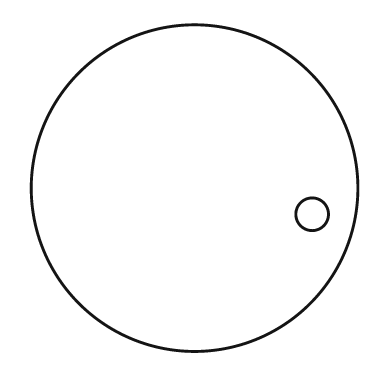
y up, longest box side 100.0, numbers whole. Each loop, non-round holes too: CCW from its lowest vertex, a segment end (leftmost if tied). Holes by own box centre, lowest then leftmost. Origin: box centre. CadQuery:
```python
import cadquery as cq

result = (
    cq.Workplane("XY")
    .moveTo(0.0, 0.0)
    .circle(50.0)
    .moveTo(36.0, -8.0)
    .circle(5.0)
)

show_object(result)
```